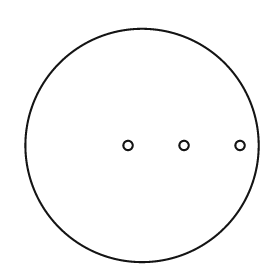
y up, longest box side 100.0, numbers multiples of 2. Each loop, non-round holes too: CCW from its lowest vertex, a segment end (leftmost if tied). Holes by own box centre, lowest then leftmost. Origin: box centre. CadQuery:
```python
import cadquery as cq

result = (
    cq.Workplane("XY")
    .moveTo(0.0, 0.0)
    .circle(50.0)
    .moveTo(-6.0, 0.0)
    .circle(2.0)
    .moveTo(18.0, 0.0)
    .circle(2.0)
    .moveTo(42.0, 0.0)
    .circle(2.0)
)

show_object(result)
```